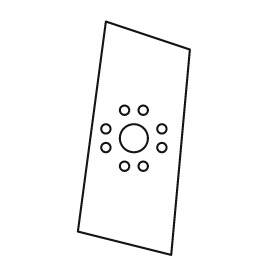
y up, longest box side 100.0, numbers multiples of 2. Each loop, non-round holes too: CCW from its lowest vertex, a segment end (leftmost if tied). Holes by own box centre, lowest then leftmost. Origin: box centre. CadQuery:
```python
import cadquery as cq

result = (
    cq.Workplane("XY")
    .moveTo(16.0, -50.0)
    .lineTo(24.0, 38.0)
    .lineTo(-12.0, 50.0)
    .lineTo(-24.0, -40.0)
    .close()
    .moveTo(-4.0, -12.0)
    .circle(2.0)
    .moveTo(4.0, -12.0)
    .circle(2.0)
    .moveTo(-12.0, -4.0)
    .circle(2.0)
    .moveTo(12.0, -4.0)
    .circle(2.0)
    .moveTo(0.0, 0.0)
    .circle(6.0)
    .moveTo(-12.0, 4.0)
    .circle(2.0)
    .moveTo(12.0, 4.0)
    .circle(2.0)
    .moveTo(-4.0, 12.0)
    .circle(2.0)
    .moveTo(4.0, 12.0)
    .circle(2.0)
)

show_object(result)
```